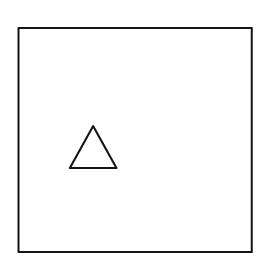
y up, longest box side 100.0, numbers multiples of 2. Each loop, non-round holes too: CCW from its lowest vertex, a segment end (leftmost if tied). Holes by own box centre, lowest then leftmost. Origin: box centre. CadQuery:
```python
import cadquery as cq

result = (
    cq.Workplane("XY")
    .moveTo(-50.0, -48.0)
    .lineTo(50.0, -48.0)
    .lineTo(50.0, 48.0)
    .lineTo(-50.0, 48.0)
    .close()
    .moveTo(-28.0, -12.0)
    .lineTo(-8.0, -12.0)
    .lineTo(-18.0, 6.0)
    .close()
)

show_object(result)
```